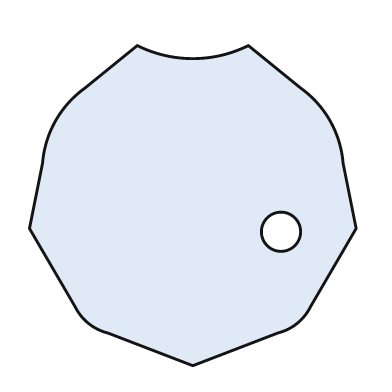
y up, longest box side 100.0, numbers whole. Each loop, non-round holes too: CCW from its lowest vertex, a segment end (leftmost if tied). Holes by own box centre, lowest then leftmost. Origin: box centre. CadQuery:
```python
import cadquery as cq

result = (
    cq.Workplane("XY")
    .moveTo(0.0, -49.0)
    .lineTo(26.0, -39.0)
    .threePointArc((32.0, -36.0), (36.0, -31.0))
    .lineTo(50.0, -7.0)
    .lineTo(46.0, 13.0)
    .threePointArc((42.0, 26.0), (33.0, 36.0))
    .lineTo(17.0, 49.0)
    .threePointArc((0.0, 45.0), (-17.0, 49.0))
    .lineTo(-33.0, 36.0)
    .threePointArc((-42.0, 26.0), (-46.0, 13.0))
    .lineTo(-50.0, -7.0)
    .lineTo(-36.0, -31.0)
    .threePointArc((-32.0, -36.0), (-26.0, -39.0))
    .close()
    .moveTo(27.0, -8.0)
    .circle(6.0)
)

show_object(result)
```